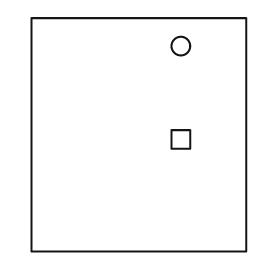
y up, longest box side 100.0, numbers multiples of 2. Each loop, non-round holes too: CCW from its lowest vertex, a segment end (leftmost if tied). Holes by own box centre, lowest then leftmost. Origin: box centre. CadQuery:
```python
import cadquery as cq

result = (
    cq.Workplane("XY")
    .moveTo(-46.0, -50.0)
    .lineTo(46.0, -50.0)
    .lineTo(46.0, 50.0)
    .lineTo(-46.0, 50.0)
    .close()
    .moveTo(14.0, -6.0)
    .lineTo(22.0, -6.0)
    .lineTo(22.0, 2.0)
    .lineTo(14.0, 2.0)
    .close()
    .moveTo(18.0, 38.0)
    .circle(4.0)
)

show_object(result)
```